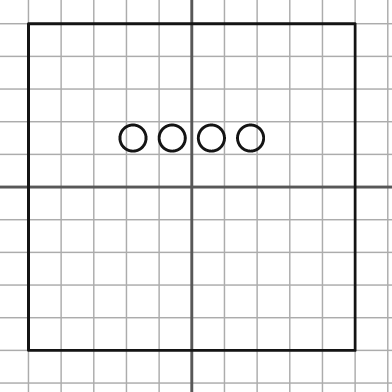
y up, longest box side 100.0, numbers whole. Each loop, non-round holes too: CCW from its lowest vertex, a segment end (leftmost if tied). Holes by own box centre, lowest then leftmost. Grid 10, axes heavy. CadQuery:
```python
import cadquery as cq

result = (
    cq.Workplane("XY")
    .moveTo(-50.0, -50.0)
    .lineTo(50.0, -50.0)
    .lineTo(50.0, 50.0)
    .lineTo(-50.0, 50.0)
    .close()
    .moveTo(-18.0, 15.0)
    .circle(4.0)
    .moveTo(-6.0, 15.0)
    .circle(4.0)
    .moveTo(6.0, 15.0)
    .circle(4.0)
    .moveTo(18.0, 15.0)
    .circle(4.0)
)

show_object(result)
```